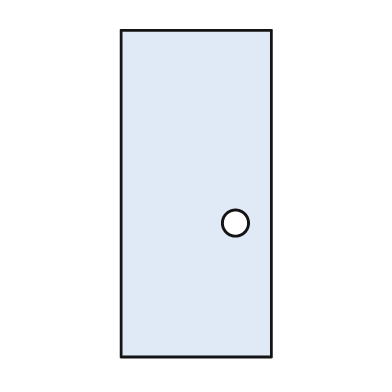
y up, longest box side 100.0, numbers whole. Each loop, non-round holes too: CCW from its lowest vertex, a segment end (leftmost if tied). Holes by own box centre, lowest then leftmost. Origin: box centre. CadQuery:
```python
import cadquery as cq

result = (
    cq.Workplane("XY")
    .moveTo(-23.0, -50.0)
    .lineTo(23.0, -50.0)
    .lineTo(23.0, 50.0)
    .lineTo(-23.0, 50.0)
    .close()
    .moveTo(12.0, -9.0)
    .circle(4.0)
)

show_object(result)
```